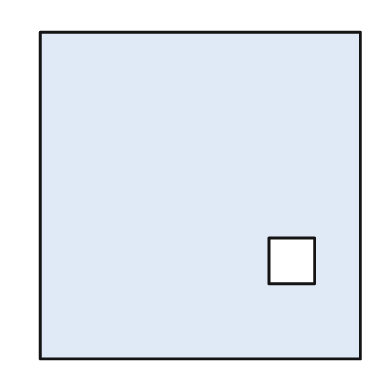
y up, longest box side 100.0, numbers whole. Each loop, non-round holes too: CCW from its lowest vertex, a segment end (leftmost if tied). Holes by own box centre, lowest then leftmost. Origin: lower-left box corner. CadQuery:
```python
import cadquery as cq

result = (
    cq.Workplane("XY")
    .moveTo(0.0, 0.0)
    .lineTo(98.0, 0.0)
    .lineTo(98.0, 100.0)
    .lineTo(0.0, 100.0)
    .close()
    .moveTo(70.0, 23.0)
    .lineTo(84.0, 23.0)
    .lineTo(84.0, 37.0)
    .lineTo(70.0, 37.0)
    .close()
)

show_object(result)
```